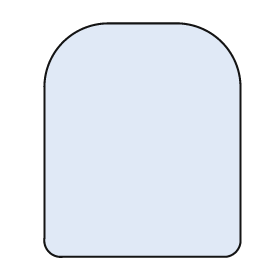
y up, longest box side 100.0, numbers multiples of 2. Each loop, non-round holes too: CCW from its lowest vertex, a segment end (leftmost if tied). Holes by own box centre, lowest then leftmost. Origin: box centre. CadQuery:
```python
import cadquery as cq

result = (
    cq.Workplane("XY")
    .moveTo(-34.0, -50.0)
    .lineTo(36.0, -50.0)
    .threePointArc((40.0, -48.0), (42.0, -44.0))
    .lineTo(42.0, 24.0)
    .threePointArc((34.0, 42.0), (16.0, 50.0))
    .lineTo(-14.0, 50.0)
    .threePointArc((-34.0, 42.0), (-42.0, 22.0))
    .lineTo(-42.0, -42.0)
    .threePointArc((-40.0, -48.0), (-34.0, -50.0))
    .close()
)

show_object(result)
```